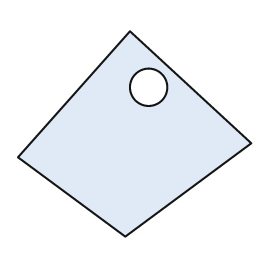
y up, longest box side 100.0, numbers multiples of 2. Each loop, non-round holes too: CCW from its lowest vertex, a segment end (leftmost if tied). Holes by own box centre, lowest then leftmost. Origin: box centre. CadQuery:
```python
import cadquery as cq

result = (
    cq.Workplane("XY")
    .moveTo(-4.0, -44.0)
    .lineTo(50.0, -4.0)
    .lineTo(-2.0, 44.0)
    .lineTo(-50.0, -10.0)
    .close()
    .moveTo(6.0, 20.0)
    .circle(8.0)
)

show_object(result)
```